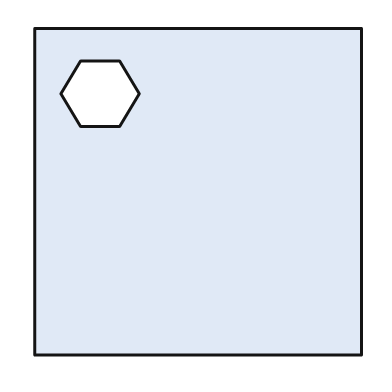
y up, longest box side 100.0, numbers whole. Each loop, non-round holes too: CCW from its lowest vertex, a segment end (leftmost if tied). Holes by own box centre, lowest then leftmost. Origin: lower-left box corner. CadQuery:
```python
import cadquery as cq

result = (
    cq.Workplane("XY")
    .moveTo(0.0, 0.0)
    .lineTo(100.0, 0.0)
    .lineTo(100.0, 100.0)
    .lineTo(0.0, 100.0)
    .close()
    .moveTo(14.0, 70.0)
    .lineTo(26.0, 70.0)
    .lineTo(32.0, 80.0)
    .lineTo(26.0, 90.0)
    .lineTo(14.0, 90.0)
    .lineTo(8.0, 80.0)
    .close()
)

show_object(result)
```